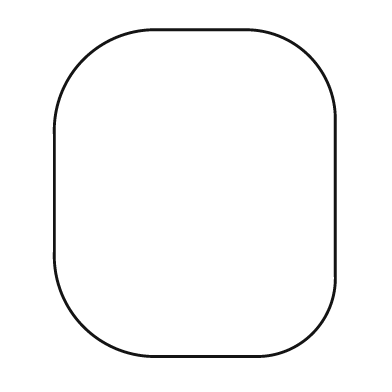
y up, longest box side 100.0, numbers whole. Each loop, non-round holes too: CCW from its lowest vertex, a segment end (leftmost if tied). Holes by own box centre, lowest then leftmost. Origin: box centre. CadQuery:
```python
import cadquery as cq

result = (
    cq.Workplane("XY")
    .moveTo(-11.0, -50.0)
    .lineTo(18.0, -50.0)
    .threePointArc((36.0, -43.0), (43.0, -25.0))
    .lineTo(43.0, 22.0)
    .threePointArc((35.0, 42.0), (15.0, 50.0))
    .lineTo(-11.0, 50.0)
    .threePointArc((-34.0, 41.0), (-43.0, 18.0))
    .lineTo(-43.0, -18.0)
    .threePointArc((-34.0, -41.0), (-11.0, -50.0))
    .close()
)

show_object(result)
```